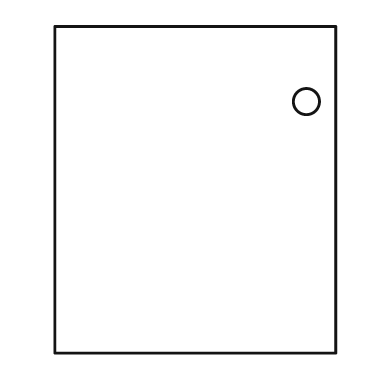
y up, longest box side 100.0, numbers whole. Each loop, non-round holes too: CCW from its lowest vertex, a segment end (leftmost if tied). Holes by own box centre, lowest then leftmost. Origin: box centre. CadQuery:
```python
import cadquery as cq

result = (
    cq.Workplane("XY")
    .moveTo(-43.0, -50.0)
    .lineTo(43.0, -50.0)
    .lineTo(43.0, 50.0)
    .lineTo(-43.0, 50.0)
    .close()
    .moveTo(34.0, 27.0)
    .circle(4.0)
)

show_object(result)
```